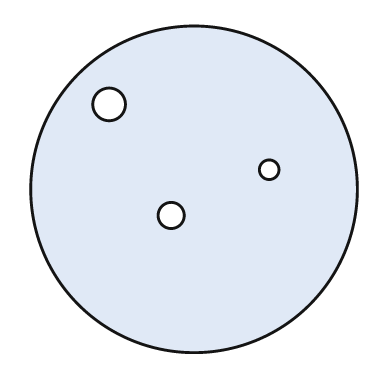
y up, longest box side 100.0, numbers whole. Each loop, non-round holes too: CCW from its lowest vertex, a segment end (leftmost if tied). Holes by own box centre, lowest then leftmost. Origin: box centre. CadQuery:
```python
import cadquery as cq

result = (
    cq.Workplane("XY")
    .moveTo(0.0, 0.0)
    .circle(50.0)
    .moveTo(-7.0, -8.0)
    .circle(4.0)
    .moveTo(23.0, 6.0)
    .circle(3.0)
    .moveTo(-26.0, 26.0)
    .circle(5.0)
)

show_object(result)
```